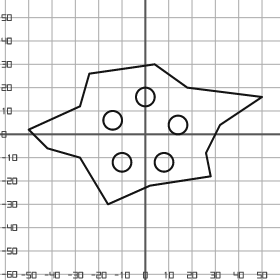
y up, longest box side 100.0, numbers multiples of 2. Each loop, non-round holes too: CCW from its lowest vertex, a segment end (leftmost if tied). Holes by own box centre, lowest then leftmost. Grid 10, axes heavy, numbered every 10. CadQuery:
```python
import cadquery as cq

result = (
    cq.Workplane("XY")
    .moveTo(-16.0, -30.0)
    .lineTo(2.0, -22.0)
    .lineTo(28.0, -18.0)
    .lineTo(26.0, -8.0)
    .lineTo(32.0, 4.0)
    .lineTo(50.0, 16.0)
    .lineTo(18.0, 20.0)
    .lineTo(4.0, 30.0)
    .lineTo(-24.0, 26.0)
    .lineTo(-28.0, 12.0)
    .lineTo(-50.0, 2.0)
    .lineTo(-42.0, -6.0)
    .lineTo(-28.0, -10.0)
    .close()
    .moveTo(-10.0, -12.0)
    .circle(4.0)
    .moveTo(8.0, -12.0)
    .circle(4.0)
    .moveTo(14.0, 4.0)
    .circle(4.0)
    .moveTo(-14.0, 6.0)
    .circle(4.0)
    .moveTo(0.0, 16.0)
    .circle(4.0)
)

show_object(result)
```